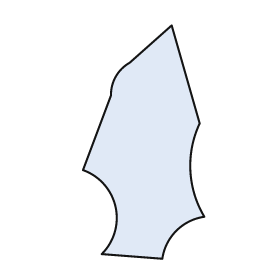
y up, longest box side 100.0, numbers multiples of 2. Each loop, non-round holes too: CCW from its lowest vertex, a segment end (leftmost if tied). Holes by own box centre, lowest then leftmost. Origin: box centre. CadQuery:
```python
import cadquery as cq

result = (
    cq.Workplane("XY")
    .moveTo(8.0, -50.0)
    .threePointArc((14.0, -38.0), (26.0, -32.0))
    .threePointArc((20.0, -12.0), (24.0, 8.0))
    .lineTo(12.0, 50.0)
    .lineTo(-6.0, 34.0)
    .threePointArc((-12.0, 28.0), (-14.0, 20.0))
    .lineTo(-26.0, -12.0)
    .threePointArc((-12.0, -28.0), (-18.0, -48.0))
    .close()
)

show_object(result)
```